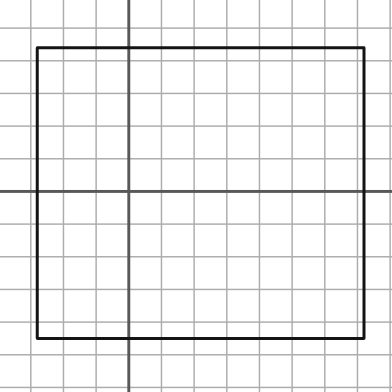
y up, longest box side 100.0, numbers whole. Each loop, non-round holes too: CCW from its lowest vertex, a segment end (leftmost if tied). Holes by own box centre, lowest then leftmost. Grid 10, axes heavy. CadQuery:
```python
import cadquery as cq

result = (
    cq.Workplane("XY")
    .moveTo(-28.0, -45.0)
    .lineTo(72.0, -45.0)
    .lineTo(72.0, 44.0)
    .lineTo(-28.0, 44.0)
    .close()
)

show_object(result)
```